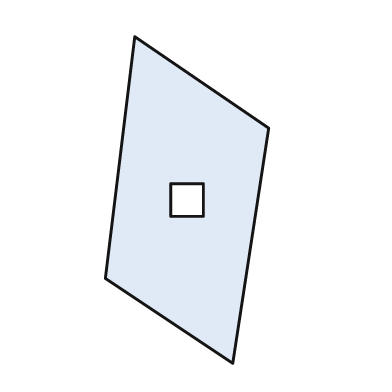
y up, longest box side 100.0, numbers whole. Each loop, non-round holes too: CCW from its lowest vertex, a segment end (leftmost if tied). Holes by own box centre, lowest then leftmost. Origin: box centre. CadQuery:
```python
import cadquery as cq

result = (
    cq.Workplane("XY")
    .moveTo(14.0, -50.0)
    .lineTo(25.0, 22.0)
    .lineTo(-16.0, 50.0)
    .lineTo(-25.0, -24.0)
    .close()
    .moveTo(-5.0, -5.0)
    .lineTo(5.0, -5.0)
    .lineTo(5.0, 5.0)
    .lineTo(-5.0, 5.0)
    .close()
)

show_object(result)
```